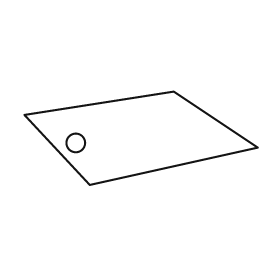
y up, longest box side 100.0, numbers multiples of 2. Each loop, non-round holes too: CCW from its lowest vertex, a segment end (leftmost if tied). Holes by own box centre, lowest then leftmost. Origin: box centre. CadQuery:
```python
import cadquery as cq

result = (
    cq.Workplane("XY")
    .moveTo(-22.0, -20.0)
    .lineTo(50.0, -4.0)
    .lineTo(14.0, 20.0)
    .lineTo(-50.0, 10.0)
    .close()
    .moveTo(-28.0, -2.0)
    .circle(4.0)
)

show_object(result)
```